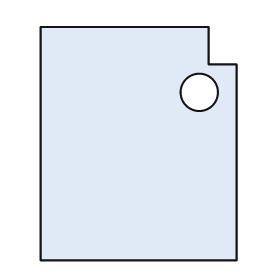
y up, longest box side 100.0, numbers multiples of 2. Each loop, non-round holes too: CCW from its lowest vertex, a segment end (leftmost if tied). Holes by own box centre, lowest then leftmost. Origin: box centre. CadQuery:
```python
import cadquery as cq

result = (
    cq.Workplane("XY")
    .moveTo(-42.0, -50.0)
    .lineTo(42.0, -50.0)
    .lineTo(42.0, 34.0)
    .lineTo(30.0, 34.0)
    .lineTo(30.0, 50.0)
    .lineTo(-42.0, 50.0)
    .close()
    .moveTo(26.0, 22.0)
    .circle(8.0)
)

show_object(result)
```